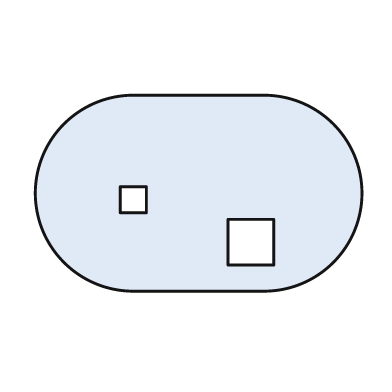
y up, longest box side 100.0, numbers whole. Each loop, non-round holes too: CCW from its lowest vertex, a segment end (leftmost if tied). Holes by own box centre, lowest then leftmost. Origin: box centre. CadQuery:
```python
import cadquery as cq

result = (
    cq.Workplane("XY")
    .moveTo(-20.0, -30.0)
    .lineTo(20.0, -30.0)
    .threePointArc((50.0, 0.0), (20.0, 30.0))
    .lineTo(-20.0, 30.0)
    .threePointArc((-50.0, 0.0), (-20.0, -30.0))
    .close()
    .moveTo(9.0, -22.0)
    .lineTo(23.0, -22.0)
    .lineTo(23.0, -8.0)
    .lineTo(9.0, -8.0)
    .close()
    .moveTo(-24.0, -6.0)
    .lineTo(-16.0, -6.0)
    .lineTo(-16.0, 2.0)
    .lineTo(-24.0, 2.0)
    .close()
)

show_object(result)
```